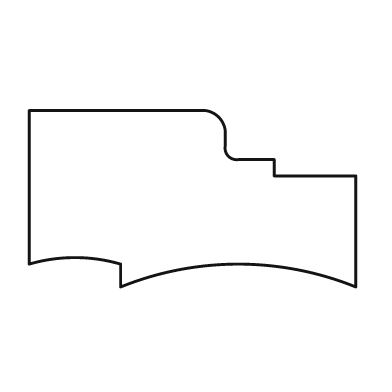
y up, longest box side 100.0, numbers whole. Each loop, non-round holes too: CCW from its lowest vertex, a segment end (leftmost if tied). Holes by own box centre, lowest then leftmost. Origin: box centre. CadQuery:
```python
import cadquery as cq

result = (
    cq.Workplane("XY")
    .moveTo(-22.0, -27.0)
    .threePointArc((14.0, -20.0), (50.0, -27.0))
    .lineTo(50.0, 7.0)
    .lineTo(25.0, 7.0)
    .lineTo(25.0, 12.0)
    .lineTo(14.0, 12.0)
    .threePointArc((11.0, 13.0), (10.0, 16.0))
    .lineTo(10.0, 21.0)
    .threePointArc((8.0, 25.0), (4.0, 27.0))
    .lineTo(-50.0, 27.0)
    .lineTo(-50.0, -20.0)
    .threePointArc((-36.0, -18.0), (-22.0, -20.0))
    .close()
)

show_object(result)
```